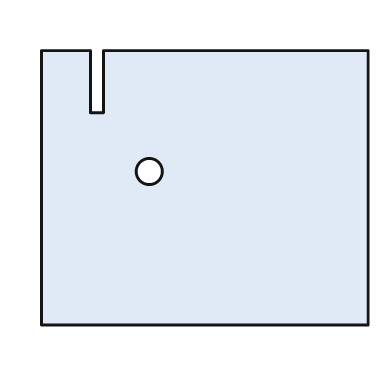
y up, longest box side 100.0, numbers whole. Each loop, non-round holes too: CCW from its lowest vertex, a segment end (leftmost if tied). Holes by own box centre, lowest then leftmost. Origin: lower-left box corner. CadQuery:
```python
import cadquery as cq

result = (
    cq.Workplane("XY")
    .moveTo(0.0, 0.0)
    .lineTo(100.0, 0.0)
    .lineTo(100.0, 84.0)
    .lineTo(19.0, 84.0)
    .lineTo(19.0, 65.0)
    .lineTo(15.0, 65.0)
    .lineTo(15.0, 84.0)
    .lineTo(0.0, 84.0)
    .close()
    .moveTo(33.0, 47.0)
    .circle(4.0)
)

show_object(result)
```